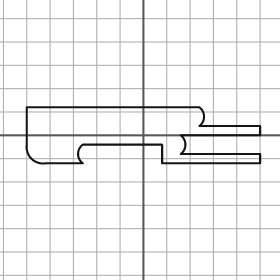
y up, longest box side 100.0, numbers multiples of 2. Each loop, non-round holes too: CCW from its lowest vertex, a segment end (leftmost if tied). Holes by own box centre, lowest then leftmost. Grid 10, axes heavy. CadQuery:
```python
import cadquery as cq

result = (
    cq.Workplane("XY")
    .moveTo(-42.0, -12.0)
    .lineTo(-26.0, -12.0)
    .threePointArc((-28.0, -8.0), (-26.0, -4.0))
    .lineTo(8.0, -4.0)
    .lineTo(8.0, -12.0)
    .lineTo(50.0, -12.0)
    .lineTo(50.0, -8.0)
    .lineTo(16.0, -8.0)
    .threePointArc((18.0, -4.0), (16.0, 0.0))
    .lineTo(50.0, 0.0)
    .lineTo(50.0, 4.0)
    .lineTo(24.0, 4.0)
    .threePointArc((26.0, 8.0), (24.0, 12.0))
    .lineTo(-50.0, 12.0)
    .lineTo(-50.0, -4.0)
    .threePointArc((-48.0, -10.0), (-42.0, -12.0))
    .close()
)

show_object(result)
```